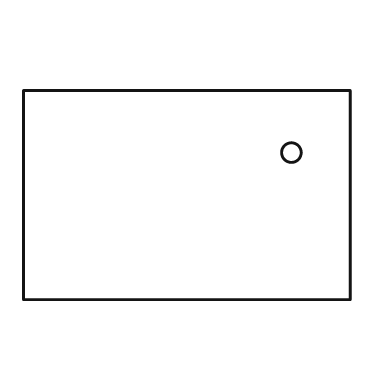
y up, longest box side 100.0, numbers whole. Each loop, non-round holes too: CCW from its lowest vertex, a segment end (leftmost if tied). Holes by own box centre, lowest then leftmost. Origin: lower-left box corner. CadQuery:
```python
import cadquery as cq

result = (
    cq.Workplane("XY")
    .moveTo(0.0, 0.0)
    .lineTo(100.0, 0.0)
    .lineTo(100.0, 64.0)
    .lineTo(0.0, 64.0)
    .close()
    .moveTo(82.0, 45.0)
    .circle(3.0)
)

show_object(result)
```